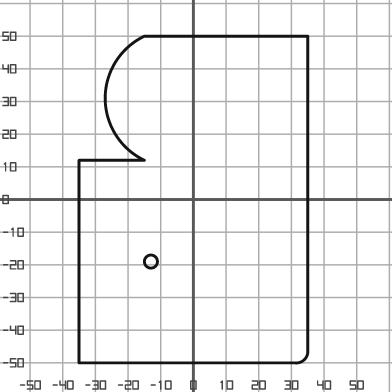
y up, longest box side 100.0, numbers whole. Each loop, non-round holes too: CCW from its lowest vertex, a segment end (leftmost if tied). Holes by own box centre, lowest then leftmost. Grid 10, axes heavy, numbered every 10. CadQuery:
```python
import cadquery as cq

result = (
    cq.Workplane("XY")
    .moveTo(-35.0, -50.0)
    .lineTo(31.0, -50.0)
    .threePointArc((34.0, -49.0), (35.0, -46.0))
    .lineTo(35.0, 50.0)
    .lineTo(-15.0, 50.0)
    .threePointArc((-27.0, 31.0), (-15.0, 12.0))
    .lineTo(-35.0, 12.0)
    .close()
    .moveTo(-13.0, -19.0)
    .circle(2.0)
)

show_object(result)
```